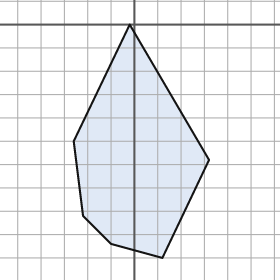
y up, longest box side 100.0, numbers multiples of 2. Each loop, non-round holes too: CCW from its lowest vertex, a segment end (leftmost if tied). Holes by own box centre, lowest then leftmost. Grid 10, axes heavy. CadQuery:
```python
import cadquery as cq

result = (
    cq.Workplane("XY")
    .moveTo(12.0, -100.0)
    .lineTo(32.0, -58.0)
    .lineTo(-2.0, 0.0)
    .lineTo(-26.0, -50.0)
    .lineTo(-22.0, -82.0)
    .lineTo(-10.0, -94.0)
    .close()
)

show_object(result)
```